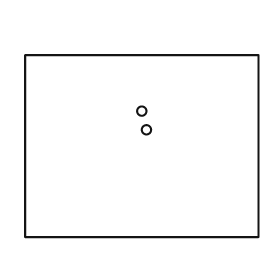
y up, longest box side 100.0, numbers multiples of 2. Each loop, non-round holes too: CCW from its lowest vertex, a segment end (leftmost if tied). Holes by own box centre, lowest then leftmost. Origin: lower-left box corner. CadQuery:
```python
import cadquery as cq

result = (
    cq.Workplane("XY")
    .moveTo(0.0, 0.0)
    .lineTo(100.0, 0.0)
    .lineTo(100.0, 78.0)
    .lineTo(0.0, 78.0)
    .close()
    .moveTo(52.0, 46.0)
    .circle(2.0)
    .moveTo(50.0, 54.0)
    .circle(2.0)
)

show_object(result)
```